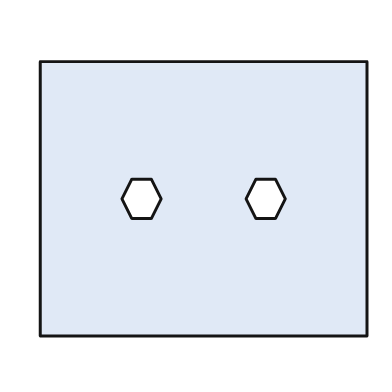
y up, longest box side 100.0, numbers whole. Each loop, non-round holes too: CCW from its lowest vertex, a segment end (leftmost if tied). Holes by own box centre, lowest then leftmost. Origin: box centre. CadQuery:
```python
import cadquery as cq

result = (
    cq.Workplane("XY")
    .moveTo(-50.0, -42.0)
    .lineTo(50.0, -42.0)
    .lineTo(50.0, 42.0)
    .lineTo(-50.0, 42.0)
    .close()
    .moveTo(-22.0, -6.0)
    .lineTo(-16.0, -6.0)
    .lineTo(-13.0, 0.0)
    .lineTo(-16.0, 6.0)
    .lineTo(-22.0, 6.0)
    .lineTo(-25.0, 0.0)
    .close()
    .moveTo(16.0, -6.0)
    .lineTo(22.0, -6.0)
    .lineTo(25.0, 0.0)
    .lineTo(22.0, 6.0)
    .lineTo(16.0, 6.0)
    .lineTo(13.0, 0.0)
    .close()
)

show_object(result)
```